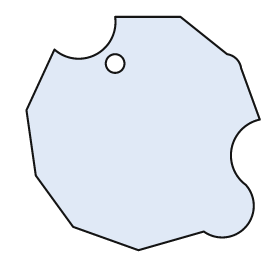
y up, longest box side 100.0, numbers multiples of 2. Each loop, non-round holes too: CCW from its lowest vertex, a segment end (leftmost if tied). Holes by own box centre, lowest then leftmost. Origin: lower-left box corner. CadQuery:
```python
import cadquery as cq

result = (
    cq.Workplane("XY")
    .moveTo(48.0, 0.0)
    .lineTo(76.0, 8.0)
    .threePointArc((94.0, 10.0), (94.0, 28.0))
    .threePointArc((88.0, 44.0), (100.0, 56.0))
    .lineTo(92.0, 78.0)
    .threePointArc((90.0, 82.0), (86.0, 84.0))
    .lineTo(66.0, 100.0)
    .lineTo(38.0, 100.0)
    .threePointArc((30.0, 84.0), (12.0, 86.0))
    .lineTo(0.0, 60.0)
    .lineTo(4.0, 32.0)
    .lineTo(20.0, 10.0)
    .close()
    .moveTo(38.0, 80.0)
    .circle(4.0)
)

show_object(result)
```